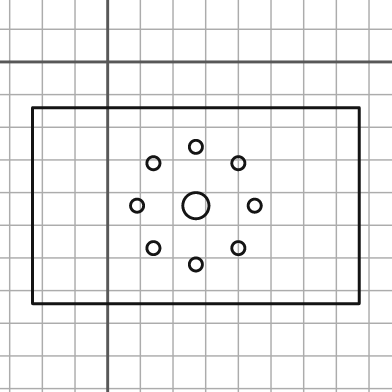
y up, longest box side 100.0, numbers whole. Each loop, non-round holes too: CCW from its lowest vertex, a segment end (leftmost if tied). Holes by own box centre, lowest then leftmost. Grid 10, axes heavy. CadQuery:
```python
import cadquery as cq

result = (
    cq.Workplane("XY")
    .moveTo(-23.0, -74.0)
    .lineTo(77.0, -74.0)
    .lineTo(77.0, -14.0)
    .lineTo(-23.0, -14.0)
    .close()
    .moveTo(27.0, -62.0)
    .circle(2.0)
    .moveTo(14.0, -57.0)
    .circle(2.0)
    .moveTo(40.0, -57.0)
    .circle(2.0)
    .moveTo(9.0, -44.0)
    .circle(2.0)
    .moveTo(27.0, -44.0)
    .circle(4.0)
    .moveTo(45.0, -44.0)
    .circle(2.0)
    .moveTo(14.0, -31.0)
    .circle(2.0)
    .moveTo(40.0, -31.0)
    .circle(2.0)
    .moveTo(27.0, -26.0)
    .circle(2.0)
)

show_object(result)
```